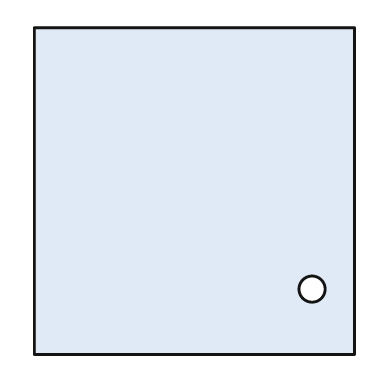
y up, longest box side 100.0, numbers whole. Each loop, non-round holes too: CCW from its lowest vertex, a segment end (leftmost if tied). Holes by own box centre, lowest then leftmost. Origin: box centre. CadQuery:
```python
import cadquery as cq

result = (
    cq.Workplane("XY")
    .moveTo(-49.0, -50.0)
    .lineTo(49.0, -50.0)
    .lineTo(49.0, 50.0)
    .lineTo(-49.0, 50.0)
    .close()
    .moveTo(36.0, -30.0)
    .circle(4.0)
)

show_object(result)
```